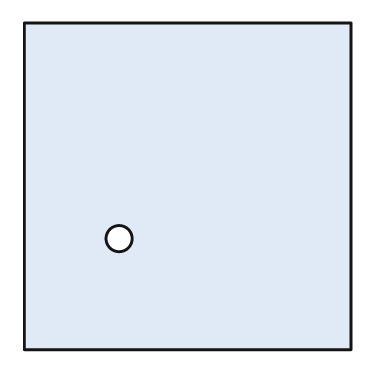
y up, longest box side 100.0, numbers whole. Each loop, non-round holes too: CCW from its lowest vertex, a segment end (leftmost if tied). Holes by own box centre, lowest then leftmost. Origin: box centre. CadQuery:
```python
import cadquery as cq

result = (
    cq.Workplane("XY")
    .moveTo(-50.0, -50.0)
    .lineTo(50.0, -50.0)
    .lineTo(50.0, 50.0)
    .lineTo(-50.0, 50.0)
    .close()
    .moveTo(-21.0, -16.0)
    .circle(4.0)
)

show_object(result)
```